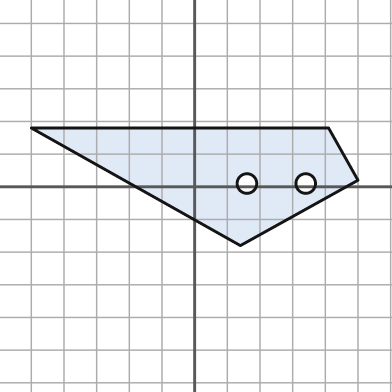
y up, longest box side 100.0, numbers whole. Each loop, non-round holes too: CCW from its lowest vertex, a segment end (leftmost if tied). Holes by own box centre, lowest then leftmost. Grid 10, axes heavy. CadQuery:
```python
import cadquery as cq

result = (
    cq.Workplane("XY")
    .moveTo(14.0, -18.0)
    .lineTo(50.0, 2.0)
    .lineTo(41.0, 18.0)
    .lineTo(-50.0, 18.0)
    .close()
    .moveTo(16.0, 1.0)
    .circle(3.0)
    .moveTo(34.0, 1.0)
    .circle(3.0)
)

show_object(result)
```